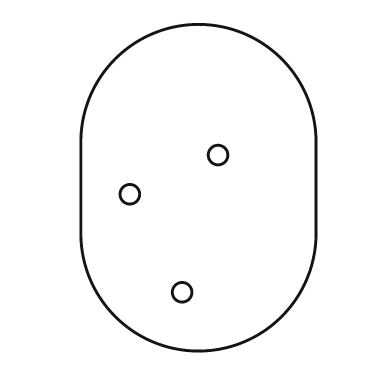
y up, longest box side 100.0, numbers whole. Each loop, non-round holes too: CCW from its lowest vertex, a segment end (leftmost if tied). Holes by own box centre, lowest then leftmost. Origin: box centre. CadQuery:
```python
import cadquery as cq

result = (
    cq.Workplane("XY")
    .moveTo(-36.0, -14.0)
    .threePointArc((0.0, -50.0), (36.0, -14.0))
    .lineTo(36.0, 14.0)
    .threePointArc((0.0, 50.0), (-36.0, 14.0))
    .close()
    .moveTo(-5.0, -32.0)
    .circle(3.0)
    .moveTo(-21.0, -2.0)
    .circle(3.0)
    .moveTo(6.0, 10.0)
    .circle(3.0)
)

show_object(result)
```